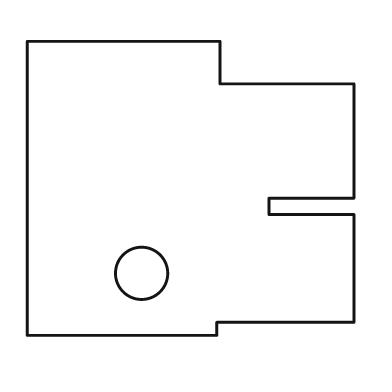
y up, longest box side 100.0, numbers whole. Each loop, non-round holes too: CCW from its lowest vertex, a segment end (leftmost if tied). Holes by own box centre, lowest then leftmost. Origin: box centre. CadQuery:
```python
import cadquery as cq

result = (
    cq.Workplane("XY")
    .moveTo(-50.0, -45.0)
    .lineTo(8.0, -45.0)
    .lineTo(8.0, -41.0)
    .lineTo(50.0, -41.0)
    .lineTo(50.0, -8.0)
    .lineTo(24.0, -8.0)
    .lineTo(24.0, -3.0)
    .lineTo(50.0, -3.0)
    .lineTo(50.0, 32.0)
    .lineTo(9.0, 32.0)
    .lineTo(9.0, 45.0)
    .lineTo(-50.0, 45.0)
    .close()
    .moveTo(-15.0, -26.0)
    .circle(8.0)
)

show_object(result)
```